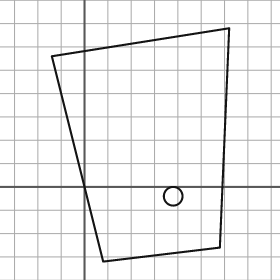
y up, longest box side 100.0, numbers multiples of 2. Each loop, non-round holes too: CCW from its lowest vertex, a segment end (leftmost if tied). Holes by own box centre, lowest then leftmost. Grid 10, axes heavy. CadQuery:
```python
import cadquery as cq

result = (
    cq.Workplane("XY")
    .moveTo(8.0, -32.0)
    .lineTo(58.0, -26.0)
    .lineTo(62.0, 68.0)
    .lineTo(-14.0, 56.0)
    .close()
    .moveTo(38.0, -4.0)
    .circle(4.0)
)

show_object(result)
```